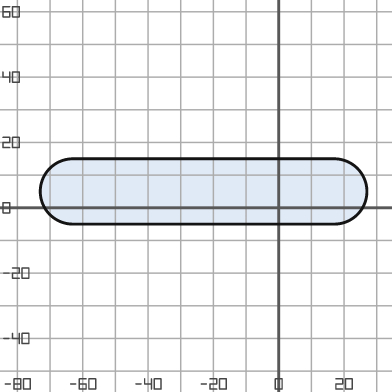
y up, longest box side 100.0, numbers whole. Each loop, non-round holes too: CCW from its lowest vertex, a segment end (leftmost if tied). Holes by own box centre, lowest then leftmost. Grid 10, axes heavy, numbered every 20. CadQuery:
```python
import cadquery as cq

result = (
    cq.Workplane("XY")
    .moveTo(-63.0, -5.0)
    .lineTo(17.0, -5.0)
    .threePointArc((27.0, 5.0), (17.0, 15.0))
    .lineTo(-63.0, 15.0)
    .threePointArc((-73.0, 5.0), (-63.0, -5.0))
    .close()
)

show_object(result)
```